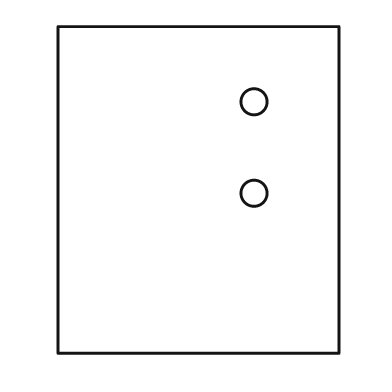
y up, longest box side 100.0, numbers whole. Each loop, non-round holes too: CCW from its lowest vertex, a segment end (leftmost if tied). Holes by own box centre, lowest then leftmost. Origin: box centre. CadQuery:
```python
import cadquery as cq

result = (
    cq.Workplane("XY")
    .moveTo(-43.0, -50.0)
    .lineTo(43.0, -50.0)
    .lineTo(43.0, 50.0)
    .lineTo(-43.0, 50.0)
    .close()
    .moveTo(17.0, -1.0)
    .circle(4.0)
    .moveTo(17.0, 27.0)
    .circle(4.0)
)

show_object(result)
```